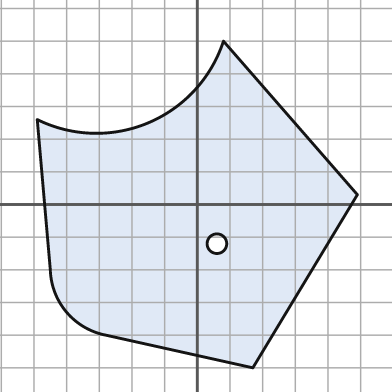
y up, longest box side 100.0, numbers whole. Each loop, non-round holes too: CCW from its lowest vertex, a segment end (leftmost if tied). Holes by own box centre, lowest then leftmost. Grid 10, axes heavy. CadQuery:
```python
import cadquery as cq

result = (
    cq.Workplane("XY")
    .moveTo(17.0, -50.0)
    .lineTo(49.0, 3.0)
    .lineTo(8.0, 50.0)
    .threePointArc((-15.0, 25.0), (-49.0, 26.0))
    .lineTo(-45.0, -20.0)
    .threePointArc((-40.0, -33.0), (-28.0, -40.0))
    .close()
    .moveTo(6.0, -12.0)
    .circle(3.0)
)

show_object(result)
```